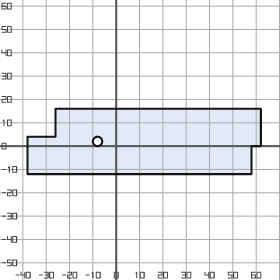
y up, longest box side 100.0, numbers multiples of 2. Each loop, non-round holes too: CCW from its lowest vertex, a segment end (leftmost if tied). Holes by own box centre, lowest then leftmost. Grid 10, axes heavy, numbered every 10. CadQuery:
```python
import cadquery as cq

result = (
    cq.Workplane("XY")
    .moveTo(-38.0, -12.0)
    .lineTo(58.0, -12.0)
    .lineTo(58.0, 0.0)
    .lineTo(62.0, 0.0)
    .lineTo(62.0, 16.0)
    .lineTo(-26.0, 16.0)
    .lineTo(-26.0, 4.0)
    .lineTo(-38.0, 4.0)
    .close()
    .moveTo(-8.0, 2.0)
    .circle(2.0)
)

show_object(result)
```